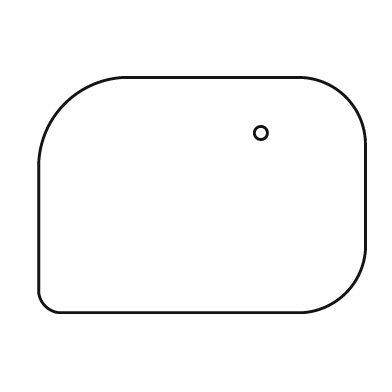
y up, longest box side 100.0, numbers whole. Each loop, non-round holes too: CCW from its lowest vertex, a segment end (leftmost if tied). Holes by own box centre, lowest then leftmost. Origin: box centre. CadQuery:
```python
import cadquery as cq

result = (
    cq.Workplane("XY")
    .moveTo(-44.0, -36.0)
    .lineTo(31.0, -36.0)
    .threePointArc((44.0, -30.0), (50.0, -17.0))
    .lineTo(50.0, 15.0)
    .threePointArc((44.0, 30.0), (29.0, 36.0))
    .lineTo(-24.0, 36.0)
    .threePointArc((-42.0, 28.0), (-50.0, 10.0))
    .lineTo(-50.0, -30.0)
    .threePointArc((-48.0, -34.0), (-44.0, -36.0))
    .close()
    .moveTo(18.0, 19.0)
    .circle(2.0)
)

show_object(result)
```